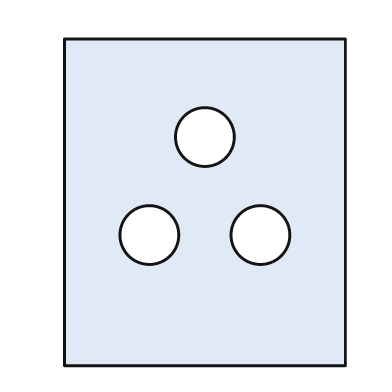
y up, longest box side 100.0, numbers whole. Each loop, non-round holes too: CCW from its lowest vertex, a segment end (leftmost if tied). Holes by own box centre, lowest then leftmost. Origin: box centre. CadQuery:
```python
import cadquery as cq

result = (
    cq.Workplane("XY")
    .moveTo(-43.0, -50.0)
    .lineTo(43.0, -50.0)
    .lineTo(43.0, 50.0)
    .lineTo(-43.0, 50.0)
    .close()
    .moveTo(-17.0, -10.0)
    .circle(9.0)
    .moveTo(17.0, -10.0)
    .circle(9.0)
    .moveTo(0.0, 20.0)
    .circle(9.0)
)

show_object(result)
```